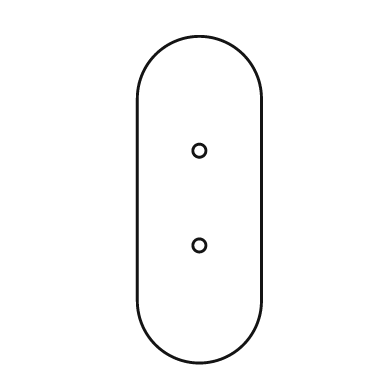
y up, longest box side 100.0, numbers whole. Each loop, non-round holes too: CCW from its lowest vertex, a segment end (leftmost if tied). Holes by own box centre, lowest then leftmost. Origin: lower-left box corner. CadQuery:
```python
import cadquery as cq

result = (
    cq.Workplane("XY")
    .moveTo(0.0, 19.0)
    .threePointArc((19.0, 0.0), (38.0, 19.0))
    .lineTo(38.0, 81.0)
    .threePointArc((19.0, 100.0), (0.0, 81.0))
    .close()
    .moveTo(19.0, 36.0)
    .circle(2.0)
    .moveTo(19.0, 65.0)
    .circle(2.0)
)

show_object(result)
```